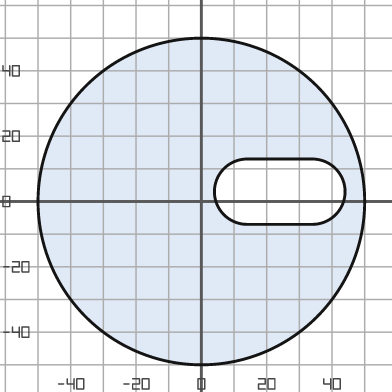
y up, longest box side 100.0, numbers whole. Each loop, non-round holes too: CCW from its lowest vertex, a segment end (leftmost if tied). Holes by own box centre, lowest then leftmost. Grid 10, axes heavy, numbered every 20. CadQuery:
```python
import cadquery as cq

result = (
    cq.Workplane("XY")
    .moveTo(0.0, 0.0)
    .circle(50.0)
    .moveTo(14.0, -7.0)
    .lineTo(34.0, -7.0)
    .threePointArc((44.0, 3.0), (34.0, 13.0))
    .lineTo(14.0, 13.0)
    .threePointArc((4.0, 3.0), (14.0, -7.0))
    .close()
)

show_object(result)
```